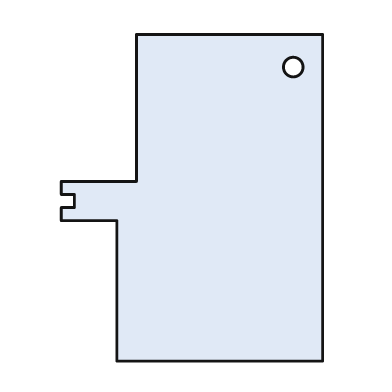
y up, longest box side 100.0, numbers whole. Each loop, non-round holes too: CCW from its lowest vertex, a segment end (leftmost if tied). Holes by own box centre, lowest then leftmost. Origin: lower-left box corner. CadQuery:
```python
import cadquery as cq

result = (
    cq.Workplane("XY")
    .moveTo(17.0, 0.0)
    .lineTo(80.0, 0.0)
    .lineTo(80.0, 100.0)
    .lineTo(23.0, 100.0)
    .lineTo(23.0, 55.0)
    .lineTo(0.0, 55.0)
    .lineTo(0.0, 51.0)
    .lineTo(4.0, 51.0)
    .lineTo(4.0, 47.0)
    .lineTo(0.0, 47.0)
    .lineTo(0.0, 43.0)
    .lineTo(17.0, 43.0)
    .close()
    .moveTo(71.0, 90.0)
    .circle(3.0)
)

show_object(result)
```